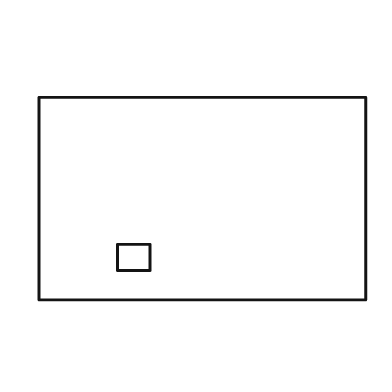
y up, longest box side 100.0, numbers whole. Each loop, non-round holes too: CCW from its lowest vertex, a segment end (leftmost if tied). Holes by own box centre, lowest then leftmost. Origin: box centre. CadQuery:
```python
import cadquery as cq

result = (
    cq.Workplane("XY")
    .moveTo(-50.0, -31.0)
    .lineTo(50.0, -31.0)
    .lineTo(50.0, 31.0)
    .lineTo(-50.0, 31.0)
    .close()
    .moveTo(-26.0, -22.0)
    .lineTo(-16.0, -22.0)
    .lineTo(-16.0, -14.0)
    .lineTo(-26.0, -14.0)
    .close()
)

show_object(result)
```